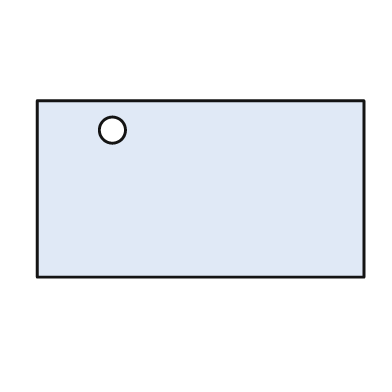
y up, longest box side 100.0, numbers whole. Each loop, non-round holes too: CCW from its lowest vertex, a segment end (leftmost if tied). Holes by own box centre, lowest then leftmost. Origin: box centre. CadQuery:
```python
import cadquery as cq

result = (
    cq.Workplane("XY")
    .moveTo(-50.0, -27.0)
    .lineTo(50.0, -27.0)
    .lineTo(50.0, 27.0)
    .lineTo(-50.0, 27.0)
    .close()
    .moveTo(-27.0, 18.0)
    .circle(4.0)
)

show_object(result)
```